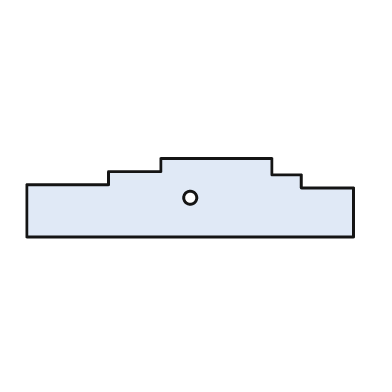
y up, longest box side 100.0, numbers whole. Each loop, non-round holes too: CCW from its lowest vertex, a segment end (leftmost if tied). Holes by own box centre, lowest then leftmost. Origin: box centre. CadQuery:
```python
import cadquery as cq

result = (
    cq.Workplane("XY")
    .moveTo(-50.0, -12.0)
    .lineTo(50.0, -12.0)
    .lineTo(50.0, 3.0)
    .lineTo(34.0, 3.0)
    .lineTo(34.0, 7.0)
    .lineTo(25.0, 7.0)
    .lineTo(25.0, 12.0)
    .lineTo(-9.0, 12.0)
    .lineTo(-9.0, 8.0)
    .lineTo(-25.0, 8.0)
    .lineTo(-25.0, 4.0)
    .lineTo(-50.0, 4.0)
    .close()
    .moveTo(0.0, 0.0)
    .circle(2.0)
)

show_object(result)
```